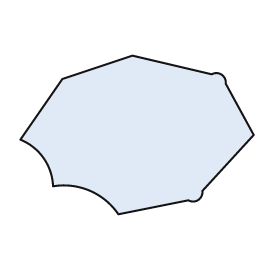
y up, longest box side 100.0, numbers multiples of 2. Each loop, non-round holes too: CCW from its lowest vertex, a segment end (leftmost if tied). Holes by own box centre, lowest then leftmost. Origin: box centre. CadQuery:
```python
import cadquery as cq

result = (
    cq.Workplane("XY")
    .moveTo(-8.0, -34.0)
    .lineTo(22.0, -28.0)
    .threePointArc((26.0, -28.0), (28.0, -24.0))
    .lineTo(50.0, 0.0)
    .lineTo(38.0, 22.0)
    .threePointArc((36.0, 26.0), (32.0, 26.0))
    .lineTo(-2.0, 34.0)
    .lineTo(-32.0, 24.0)
    .lineTo(-50.0, -2.0)
    .threePointArc((-40.0, -10.0), (-36.0, -22.0))
    .threePointArc((-20.0, -24.0), (-8.0, -34.0))
    .close()
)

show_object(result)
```